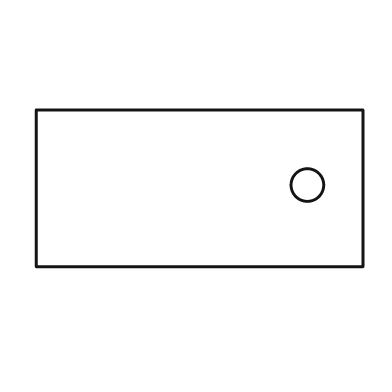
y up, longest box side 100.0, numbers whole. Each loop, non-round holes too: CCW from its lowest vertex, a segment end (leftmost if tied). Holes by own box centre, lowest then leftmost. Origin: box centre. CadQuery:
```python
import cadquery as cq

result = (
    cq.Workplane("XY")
    .moveTo(-50.0, -24.0)
    .lineTo(50.0, -24.0)
    .lineTo(50.0, 24.0)
    .lineTo(-50.0, 24.0)
    .close()
    .moveTo(33.0, 1.0)
    .circle(5.0)
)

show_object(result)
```